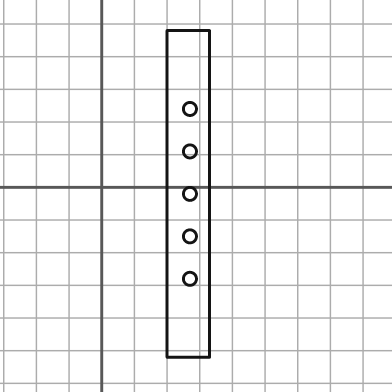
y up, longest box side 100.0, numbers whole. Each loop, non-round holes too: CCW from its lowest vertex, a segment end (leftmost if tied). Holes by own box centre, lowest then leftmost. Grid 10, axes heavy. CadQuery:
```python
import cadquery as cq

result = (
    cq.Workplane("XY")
    .moveTo(20.0, -52.0)
    .lineTo(33.0, -52.0)
    .lineTo(33.0, 48.0)
    .lineTo(20.0, 48.0)
    .close()
    .moveTo(27.0, -28.0)
    .circle(2.0)
    .moveTo(27.0, -15.0)
    .circle(2.0)
    .moveTo(27.0, -2.0)
    .circle(2.0)
    .moveTo(27.0, 11.0)
    .circle(2.0)
    .moveTo(27.0, 24.0)
    .circle(2.0)
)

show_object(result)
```